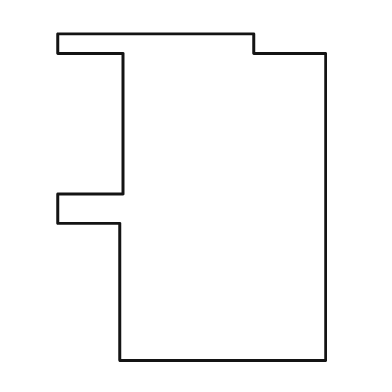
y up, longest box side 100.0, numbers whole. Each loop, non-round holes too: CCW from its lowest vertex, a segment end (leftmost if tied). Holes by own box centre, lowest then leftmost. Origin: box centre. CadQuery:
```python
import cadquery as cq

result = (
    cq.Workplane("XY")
    .moveTo(-22.0, -50.0)
    .lineTo(41.0, -50.0)
    .lineTo(41.0, 44.0)
    .lineTo(19.0, 44.0)
    .lineTo(19.0, 50.0)
    .lineTo(-41.0, 50.0)
    .lineTo(-41.0, 44.0)
    .lineTo(-21.0, 44.0)
    .lineTo(-21.0, 1.0)
    .lineTo(-41.0, 1.0)
    .lineTo(-41.0, -8.0)
    .lineTo(-22.0, -8.0)
    .close()
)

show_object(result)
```